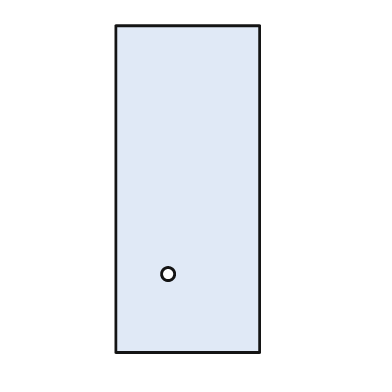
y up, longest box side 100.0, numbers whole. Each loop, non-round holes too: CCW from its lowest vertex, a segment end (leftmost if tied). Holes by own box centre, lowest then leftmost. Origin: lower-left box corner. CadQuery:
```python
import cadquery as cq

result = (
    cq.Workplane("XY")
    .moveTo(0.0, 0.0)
    .lineTo(44.0, 0.0)
    .lineTo(44.0, 100.0)
    .lineTo(0.0, 100.0)
    .close()
    .moveTo(16.0, 24.0)
    .circle(2.0)
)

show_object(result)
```